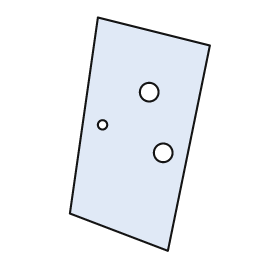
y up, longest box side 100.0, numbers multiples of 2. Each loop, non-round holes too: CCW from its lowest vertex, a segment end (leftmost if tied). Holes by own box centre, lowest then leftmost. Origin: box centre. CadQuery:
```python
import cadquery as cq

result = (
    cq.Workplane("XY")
    .moveTo(12.0, -50.0)
    .lineTo(30.0, 38.0)
    .lineTo(-18.0, 50.0)
    .lineTo(-30.0, -34.0)
    .close()
    .moveTo(10.0, -8.0)
    .circle(4.0)
    .moveTo(-16.0, 4.0)
    .circle(2.0)
    .moveTo(4.0, 18.0)
    .circle(4.0)
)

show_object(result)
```